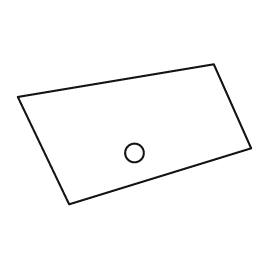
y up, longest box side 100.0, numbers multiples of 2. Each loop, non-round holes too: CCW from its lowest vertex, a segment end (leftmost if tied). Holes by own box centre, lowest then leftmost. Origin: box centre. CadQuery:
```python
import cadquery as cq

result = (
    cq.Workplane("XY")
    .moveTo(-28.0, -30.0)
    .lineTo(50.0, -6.0)
    .lineTo(34.0, 30.0)
    .lineTo(-50.0, 16.0)
    .close()
    .moveTo(0.0, -8.0)
    .circle(4.0)
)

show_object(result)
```